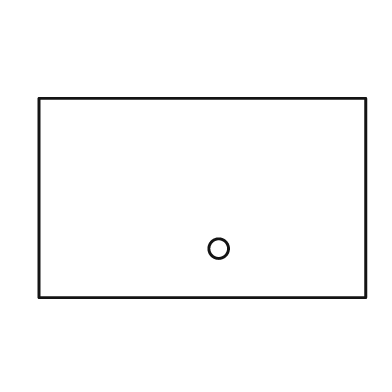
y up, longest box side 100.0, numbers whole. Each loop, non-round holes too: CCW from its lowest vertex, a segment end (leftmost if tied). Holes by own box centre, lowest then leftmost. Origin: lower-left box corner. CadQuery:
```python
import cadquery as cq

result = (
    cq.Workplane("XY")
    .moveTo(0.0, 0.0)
    .lineTo(100.0, 0.0)
    .lineTo(100.0, 61.0)
    .lineTo(0.0, 61.0)
    .close()
    .moveTo(55.0, 15.0)
    .circle(3.0)
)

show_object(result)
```